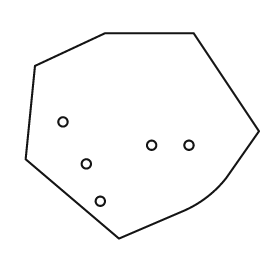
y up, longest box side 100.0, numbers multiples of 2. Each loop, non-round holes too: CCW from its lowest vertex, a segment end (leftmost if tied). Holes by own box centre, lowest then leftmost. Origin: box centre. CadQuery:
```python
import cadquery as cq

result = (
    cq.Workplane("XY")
    .moveTo(-10.0, -44.0)
    .lineTo(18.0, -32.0)
    .threePointArc((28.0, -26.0), (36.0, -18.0))
    .lineTo(50.0, 2.0)
    .lineTo(22.0, 44.0)
    .lineTo(-16.0, 44.0)
    .lineTo(-46.0, 30.0)
    .lineTo(-50.0, -10.0)
    .close()
    .moveTo(-18.0, -28.0)
    .circle(2.0)
    .moveTo(-24.0, -12.0)
    .circle(2.0)
    .moveTo(4.0, -4.0)
    .circle(2.0)
    .moveTo(20.0, -4.0)
    .circle(2.0)
    .moveTo(-34.0, 6.0)
    .circle(2.0)
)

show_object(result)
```